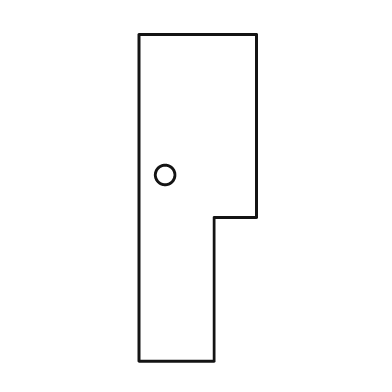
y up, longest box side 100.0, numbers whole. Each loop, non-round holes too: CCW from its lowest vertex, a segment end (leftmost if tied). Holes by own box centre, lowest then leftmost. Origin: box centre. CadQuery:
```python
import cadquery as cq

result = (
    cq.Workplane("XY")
    .moveTo(-18.0, -50.0)
    .lineTo(5.0, -50.0)
    .lineTo(5.0, -6.0)
    .lineTo(18.0, -6.0)
    .lineTo(18.0, 50.0)
    .lineTo(-18.0, 50.0)
    .close()
    .moveTo(-10.0, 7.0)
    .circle(3.0)
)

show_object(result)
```